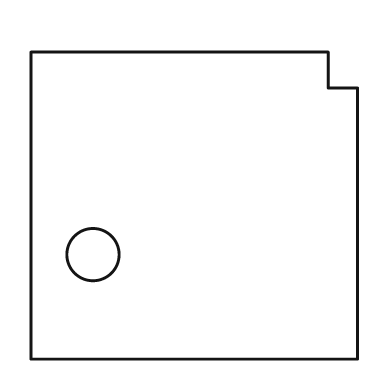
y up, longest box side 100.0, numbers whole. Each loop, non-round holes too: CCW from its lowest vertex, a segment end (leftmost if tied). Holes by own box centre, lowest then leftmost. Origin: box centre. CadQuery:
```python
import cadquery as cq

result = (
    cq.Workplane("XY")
    .moveTo(-50.0, -47.0)
    .lineTo(50.0, -47.0)
    .lineTo(50.0, 36.0)
    .lineTo(41.0, 36.0)
    .lineTo(41.0, 47.0)
    .lineTo(-50.0, 47.0)
    .close()
    .moveTo(-31.0, -15.0)
    .circle(8.0)
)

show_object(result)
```